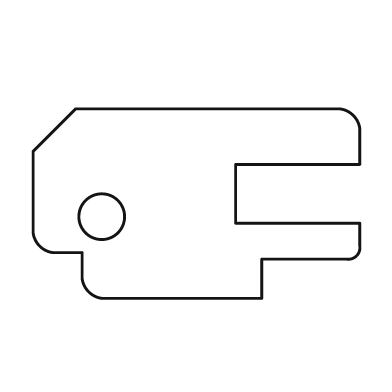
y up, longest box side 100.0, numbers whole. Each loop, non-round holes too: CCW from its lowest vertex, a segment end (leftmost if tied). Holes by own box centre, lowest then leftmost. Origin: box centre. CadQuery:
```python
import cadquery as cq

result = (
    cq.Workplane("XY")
    .moveTo(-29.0, -29.0)
    .lineTo(20.0, -29.0)
    .lineTo(20.0, -17.0)
    .lineTo(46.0, -17.0)
    .threePointArc((49.0, -16.0), (50.0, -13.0))
    .lineTo(50.0, -6.0)
    .lineTo(12.0, -6.0)
    .lineTo(12.0, 12.0)
    .lineTo(50.0, 12.0)
    .lineTo(50.0, 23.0)
    .threePointArc((48.0, 27.0), (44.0, 29.0))
    .lineTo(-37.0, 29.0)
    .lineTo(-50.0, 16.0)
    .lineTo(-50.0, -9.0)
    .threePointArc((-48.0, -13.0), (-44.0, -15.0))
    .lineTo(-35.0, -15.0)
    .lineTo(-35.0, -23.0)
    .threePointArc((-33.0, -27.0), (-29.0, -29.0))
    .close()
    .moveTo(-29.0, -4.0)
    .circle(7.0)
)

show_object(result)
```